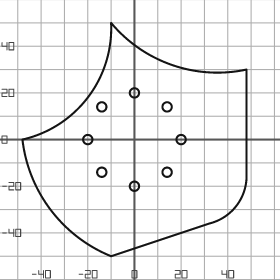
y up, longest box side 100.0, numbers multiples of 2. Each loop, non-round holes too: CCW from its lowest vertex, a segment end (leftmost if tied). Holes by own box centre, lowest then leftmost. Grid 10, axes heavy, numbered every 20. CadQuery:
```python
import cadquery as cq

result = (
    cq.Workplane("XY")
    .moveTo(-10.0, -50.0)
    .lineTo(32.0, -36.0)
    .threePointArc((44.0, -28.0), (48.0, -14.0))
    .lineTo(48.0, 30.0)
    .threePointArc((16.0, 32.0), (-10.0, 50.0))
    .threePointArc((-20.0, 18.0), (-48.0, 0.0))
    .threePointArc((-36.0, -30.0), (-10.0, -50.0))
    .close()
    .moveTo(0.0, -20.0)
    .circle(2.0)
    .moveTo(-14.0, -14.0)
    .circle(2.0)
    .moveTo(14.0, -14.0)
    .circle(2.0)
    .moveTo(-20.0, 0.0)
    .circle(2.0)
    .moveTo(20.0, 0.0)
    .circle(2.0)
    .moveTo(-14.0, 14.0)
    .circle(2.0)
    .moveTo(14.0, 14.0)
    .circle(2.0)
    .moveTo(0.0, 20.0)
    .circle(2.0)
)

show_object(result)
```